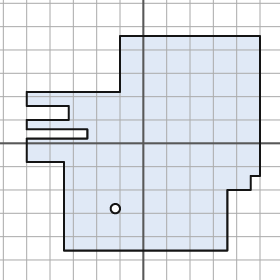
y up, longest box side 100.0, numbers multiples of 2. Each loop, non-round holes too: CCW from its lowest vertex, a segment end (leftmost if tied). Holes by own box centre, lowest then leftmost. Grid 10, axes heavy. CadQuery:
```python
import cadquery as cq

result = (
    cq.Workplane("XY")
    .moveTo(-34.0, -46.0)
    .lineTo(36.0, -46.0)
    .lineTo(36.0, -20.0)
    .lineTo(46.0, -20.0)
    .lineTo(46.0, -14.0)
    .lineTo(50.0, -14.0)
    .lineTo(50.0, 46.0)
    .lineTo(-10.0, 46.0)
    .lineTo(-10.0, 22.0)
    .lineTo(-50.0, 22.0)
    .lineTo(-50.0, 16.0)
    .lineTo(-32.0, 16.0)
    .lineTo(-32.0, 10.0)
    .lineTo(-50.0, 10.0)
    .lineTo(-50.0, 6.0)
    .lineTo(-24.0, 6.0)
    .lineTo(-24.0, 2.0)
    .lineTo(-50.0, 2.0)
    .lineTo(-50.0, -8.0)
    .lineTo(-34.0, -8.0)
    .close()
    .moveTo(-12.0, -28.0)
    .circle(2.0)
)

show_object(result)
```